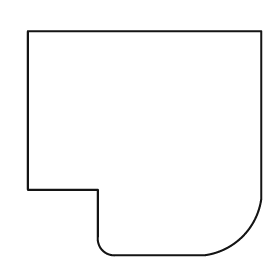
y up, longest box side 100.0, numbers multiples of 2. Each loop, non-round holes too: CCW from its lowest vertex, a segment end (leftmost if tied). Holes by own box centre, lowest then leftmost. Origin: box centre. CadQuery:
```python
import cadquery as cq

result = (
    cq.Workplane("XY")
    .moveTo(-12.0, -48.0)
    .lineTo(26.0, -48.0)
    .threePointArc((42.0, -40.0), (50.0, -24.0))
    .lineTo(50.0, 48.0)
    .lineTo(-50.0, 48.0)
    .lineTo(-50.0, -20.0)
    .lineTo(-20.0, -20.0)
    .lineTo(-20.0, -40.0)
    .threePointArc((-18.0, -46.0), (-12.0, -48.0))
    .close()
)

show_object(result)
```